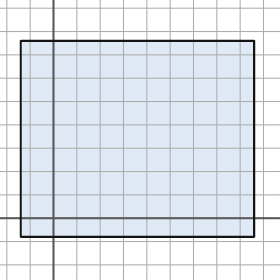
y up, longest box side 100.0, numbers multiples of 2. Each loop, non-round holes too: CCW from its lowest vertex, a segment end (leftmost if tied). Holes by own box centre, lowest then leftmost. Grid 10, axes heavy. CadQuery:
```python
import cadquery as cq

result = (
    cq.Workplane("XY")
    .moveTo(-14.0, -8.0)
    .lineTo(86.0, -8.0)
    .lineTo(86.0, 76.0)
    .lineTo(-14.0, 76.0)
    .close()
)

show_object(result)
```